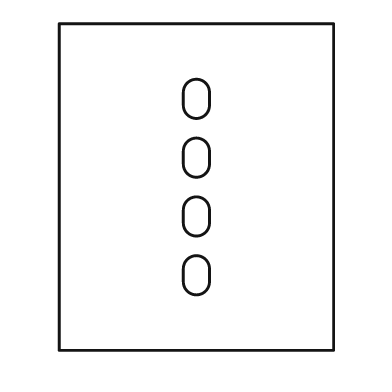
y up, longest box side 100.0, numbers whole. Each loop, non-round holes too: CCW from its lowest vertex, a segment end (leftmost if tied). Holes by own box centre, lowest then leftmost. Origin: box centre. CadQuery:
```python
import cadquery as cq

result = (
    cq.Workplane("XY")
    .moveTo(-42.0, -50.0)
    .lineTo(42.0, -50.0)
    .lineTo(42.0, 50.0)
    .lineTo(-42.0, 50.0)
    .close()
    .moveTo(-4.0, -29.0)
    .threePointArc((0.0, -33.0), (4.0, -29.0))
    .lineTo(4.0, -25.0)
    .threePointArc((0.0, -21.0), (-4.0, -25.0))
    .close()
    .moveTo(-4.0, -11.0)
    .threePointArc((0.0, -15.0), (4.0, -11.0))
    .lineTo(4.0, -7.0)
    .threePointArc((0.0, -3.0), (-4.0, -7.0))
    .close()
    .moveTo(-4.0, 7.0)
    .threePointArc((0.0, 3.0), (4.0, 7.0))
    .lineTo(4.0, 11.0)
    .threePointArc((0.0, 15.0), (-4.0, 11.0))
    .close()
    .moveTo(-4.0, 25.0)
    .threePointArc((0.0, 21.0), (4.0, 25.0))
    .lineTo(4.0, 29.0)
    .threePointArc((0.0, 33.0), (-4.0, 29.0))
    .close()
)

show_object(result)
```